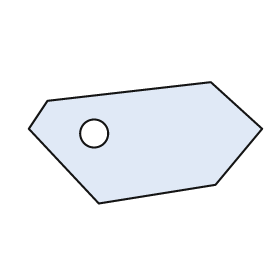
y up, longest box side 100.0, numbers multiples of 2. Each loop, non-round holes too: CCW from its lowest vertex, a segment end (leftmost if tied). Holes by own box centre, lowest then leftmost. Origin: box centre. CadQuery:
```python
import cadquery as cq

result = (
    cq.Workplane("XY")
    .moveTo(-20.0, -26.0)
    .lineTo(30.0, -18.0)
    .lineTo(50.0, 6.0)
    .lineTo(28.0, 26.0)
    .lineTo(-42.0, 18.0)
    .lineTo(-50.0, 6.0)
    .close()
    .moveTo(-22.0, 4.0)
    .circle(6.0)
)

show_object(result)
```